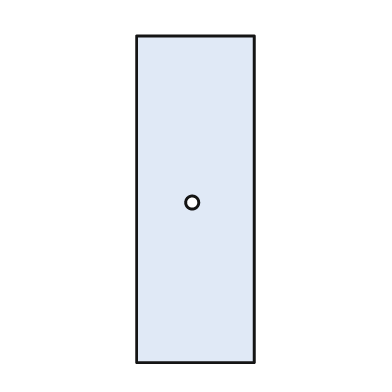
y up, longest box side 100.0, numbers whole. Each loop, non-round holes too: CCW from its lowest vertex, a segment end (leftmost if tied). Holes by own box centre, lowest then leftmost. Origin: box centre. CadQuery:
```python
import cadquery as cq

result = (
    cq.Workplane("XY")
    .moveTo(-18.0, -50.0)
    .lineTo(18.0, -50.0)
    .lineTo(18.0, 50.0)
    .lineTo(-18.0, 50.0)
    .close()
    .moveTo(-1.0, -1.0)
    .circle(2.0)
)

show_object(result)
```